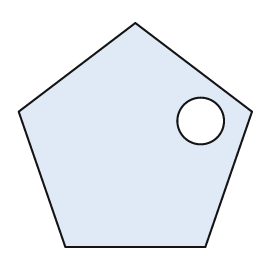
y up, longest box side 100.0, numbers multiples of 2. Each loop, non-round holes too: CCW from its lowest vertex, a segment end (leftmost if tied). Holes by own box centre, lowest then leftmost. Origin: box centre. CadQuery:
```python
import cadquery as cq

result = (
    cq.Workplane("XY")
    .moveTo(-30.0, -48.0)
    .lineTo(30.0, -48.0)
    .lineTo(50.0, 10.0)
    .lineTo(0.0, 48.0)
    .lineTo(-50.0, 10.0)
    .close()
    .moveTo(28.0, 6.0)
    .circle(10.0)
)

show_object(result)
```